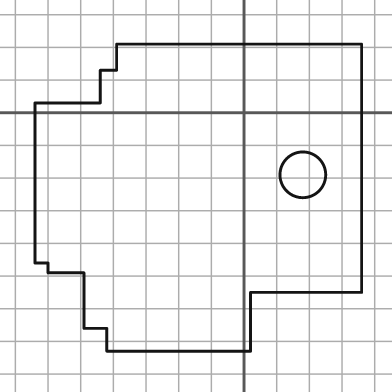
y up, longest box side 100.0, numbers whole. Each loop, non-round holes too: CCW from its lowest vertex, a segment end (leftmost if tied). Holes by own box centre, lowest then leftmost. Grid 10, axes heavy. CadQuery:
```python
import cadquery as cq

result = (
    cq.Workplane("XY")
    .moveTo(-42.0, -73.0)
    .lineTo(2.0, -73.0)
    .lineTo(2.0, -55.0)
    .lineTo(36.0, -55.0)
    .lineTo(36.0, 21.0)
    .lineTo(-39.0, 21.0)
    .lineTo(-39.0, 13.0)
    .lineTo(-44.0, 13.0)
    .lineTo(-44.0, 3.0)
    .lineTo(-64.0, 3.0)
    .lineTo(-64.0, -46.0)
    .lineTo(-60.0, -46.0)
    .lineTo(-60.0, -49.0)
    .lineTo(-49.0, -49.0)
    .lineTo(-49.0, -66.0)
    .lineTo(-42.0, -66.0)
    .close()
    .moveTo(18.0, -19.0)
    .circle(7.0)
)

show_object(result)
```